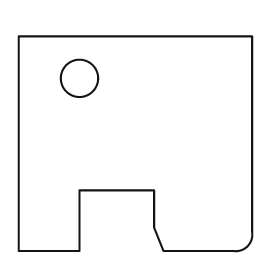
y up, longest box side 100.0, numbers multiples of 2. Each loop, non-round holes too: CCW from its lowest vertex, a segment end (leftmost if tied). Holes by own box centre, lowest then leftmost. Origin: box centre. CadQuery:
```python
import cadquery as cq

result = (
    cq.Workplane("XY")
    .moveTo(-50.0, -46.0)
    .lineTo(-24.0, -46.0)
    .lineTo(-24.0, -20.0)
    .lineTo(8.0, -20.0)
    .lineTo(8.0, -36.0)
    .lineTo(12.0, -46.0)
    .lineTo(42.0, -46.0)
    .threePointArc((48.0, -44.0), (50.0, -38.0))
    .lineTo(50.0, 46.0)
    .lineTo(-50.0, 46.0)
    .close()
    .moveTo(-24.0, 28.0)
    .circle(8.0)
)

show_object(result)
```